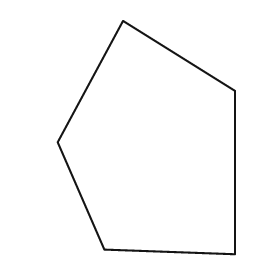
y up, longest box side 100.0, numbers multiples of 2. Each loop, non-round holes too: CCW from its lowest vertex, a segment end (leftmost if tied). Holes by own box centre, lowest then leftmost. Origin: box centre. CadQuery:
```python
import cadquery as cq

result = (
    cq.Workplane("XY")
    .moveTo(38.0, -50.0)
    .lineTo(38.0, 20.0)
    .lineTo(-10.0, 50.0)
    .lineTo(-38.0, -2.0)
    .lineTo(-18.0, -48.0)
    .close()
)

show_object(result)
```